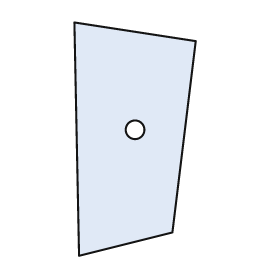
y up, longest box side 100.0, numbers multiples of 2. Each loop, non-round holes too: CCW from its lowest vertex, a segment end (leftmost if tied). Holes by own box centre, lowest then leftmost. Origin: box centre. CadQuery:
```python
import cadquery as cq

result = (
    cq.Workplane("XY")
    .moveTo(-24.0, -50.0)
    .lineTo(16.0, -40.0)
    .lineTo(26.0, 42.0)
    .lineTo(-26.0, 50.0)
    .close()
    .moveTo(0.0, 4.0)
    .circle(4.0)
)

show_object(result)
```